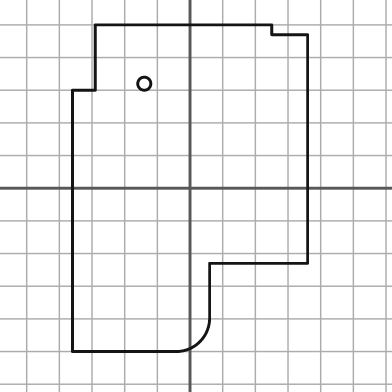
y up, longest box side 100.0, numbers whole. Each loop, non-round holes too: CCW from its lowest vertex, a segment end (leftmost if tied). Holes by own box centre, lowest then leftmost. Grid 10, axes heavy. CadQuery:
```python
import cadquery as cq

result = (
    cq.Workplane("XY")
    .moveTo(-36.0, -50.0)
    .lineTo(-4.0, -50.0)
    .threePointArc((3.0, -47.0), (6.0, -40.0))
    .lineTo(6.0, -23.0)
    .lineTo(36.0, -23.0)
    .lineTo(36.0, 47.0)
    .lineTo(25.0, 47.0)
    .lineTo(25.0, 50.0)
    .lineTo(-29.0, 50.0)
    .lineTo(-29.0, 30.0)
    .lineTo(-36.0, 30.0)
    .close()
    .moveTo(-14.0, 32.0)
    .circle(2.0)
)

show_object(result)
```